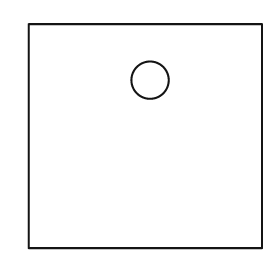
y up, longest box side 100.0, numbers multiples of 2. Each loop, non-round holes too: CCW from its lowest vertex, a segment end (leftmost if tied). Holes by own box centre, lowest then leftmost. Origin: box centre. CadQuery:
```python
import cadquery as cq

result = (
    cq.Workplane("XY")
    .moveTo(-50.0, -48.0)
    .lineTo(50.0, -48.0)
    .lineTo(50.0, 48.0)
    .lineTo(-50.0, 48.0)
    .close()
    .moveTo(2.0, 24.0)
    .circle(8.0)
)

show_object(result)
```